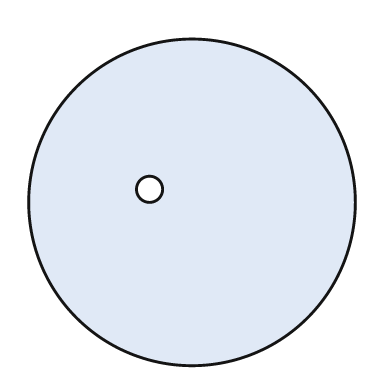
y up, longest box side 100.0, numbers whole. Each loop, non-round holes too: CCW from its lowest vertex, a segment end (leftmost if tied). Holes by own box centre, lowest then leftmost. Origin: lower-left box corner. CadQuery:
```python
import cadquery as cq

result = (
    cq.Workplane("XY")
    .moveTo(50.0, 50.0)
    .circle(50.0)
    .moveTo(37.0, 54.0)
    .circle(4.0)
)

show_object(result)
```